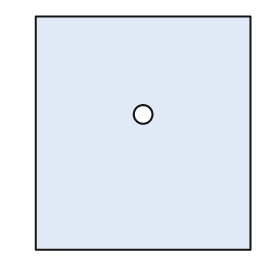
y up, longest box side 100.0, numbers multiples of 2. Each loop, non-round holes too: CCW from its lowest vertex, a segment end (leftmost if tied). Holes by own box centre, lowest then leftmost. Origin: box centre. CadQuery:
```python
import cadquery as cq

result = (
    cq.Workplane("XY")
    .moveTo(-46.0, -50.0)
    .lineTo(46.0, -50.0)
    .lineTo(46.0, 50.0)
    .lineTo(-46.0, 50.0)
    .close()
    .moveTo(0.0, 8.0)
    .circle(4.0)
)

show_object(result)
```